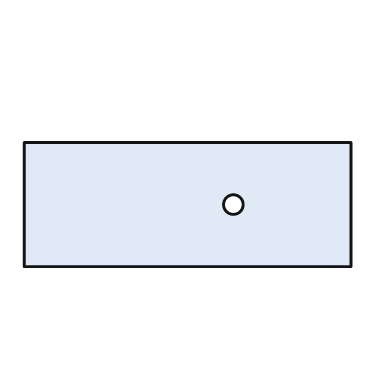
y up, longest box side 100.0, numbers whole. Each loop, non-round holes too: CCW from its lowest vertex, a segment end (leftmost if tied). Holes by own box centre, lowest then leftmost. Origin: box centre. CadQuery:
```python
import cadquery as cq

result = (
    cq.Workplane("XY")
    .moveTo(-50.0, -19.0)
    .lineTo(50.0, -19.0)
    .lineTo(50.0, 19.0)
    .lineTo(-50.0, 19.0)
    .close()
    .moveTo(14.0, 0.0)
    .circle(3.0)
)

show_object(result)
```